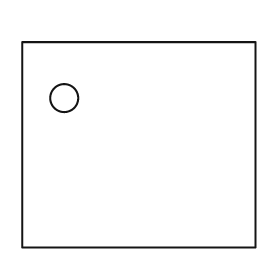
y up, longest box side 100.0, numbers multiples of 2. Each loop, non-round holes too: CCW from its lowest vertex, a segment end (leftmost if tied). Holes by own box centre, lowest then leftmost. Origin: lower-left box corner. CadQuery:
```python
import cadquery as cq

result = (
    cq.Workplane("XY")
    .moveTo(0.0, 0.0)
    .lineTo(100.0, 0.0)
    .lineTo(100.0, 88.0)
    .lineTo(0.0, 88.0)
    .close()
    .moveTo(18.0, 64.0)
    .circle(6.0)
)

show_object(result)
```